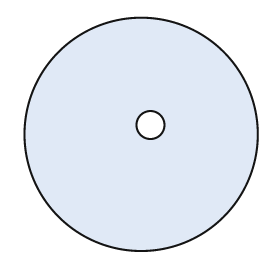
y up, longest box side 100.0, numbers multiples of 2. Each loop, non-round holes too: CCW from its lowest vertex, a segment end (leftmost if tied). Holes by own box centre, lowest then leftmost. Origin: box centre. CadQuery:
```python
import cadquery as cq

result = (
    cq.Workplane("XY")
    .moveTo(0.0, 0.0)
    .circle(50.0)
    .moveTo(4.0, 4.0)
    .circle(6.0)
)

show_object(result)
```